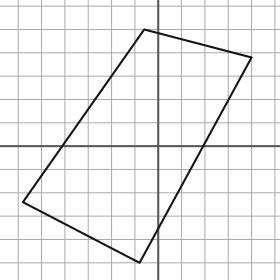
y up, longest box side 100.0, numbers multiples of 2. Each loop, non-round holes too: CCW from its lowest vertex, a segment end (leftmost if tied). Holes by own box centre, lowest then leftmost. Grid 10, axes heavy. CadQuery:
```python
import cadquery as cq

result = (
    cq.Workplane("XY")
    .moveTo(-8.0, -50.0)
    .lineTo(40.0, 38.0)
    .lineTo(-6.0, 50.0)
    .lineTo(-58.0, -24.0)
    .close()
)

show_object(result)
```